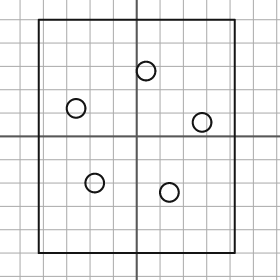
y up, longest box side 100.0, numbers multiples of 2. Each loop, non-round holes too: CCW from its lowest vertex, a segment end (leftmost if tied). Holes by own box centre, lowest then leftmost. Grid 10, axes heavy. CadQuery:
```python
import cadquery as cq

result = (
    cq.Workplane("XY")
    .moveTo(-42.0, -50.0)
    .lineTo(42.0, -50.0)
    .lineTo(42.0, 50.0)
    .lineTo(-42.0, 50.0)
    .close()
    .moveTo(14.0, -24.0)
    .circle(4.0)
    .moveTo(-18.0, -20.0)
    .circle(4.0)
    .moveTo(28.0, 6.0)
    .circle(4.0)
    .moveTo(-26.0, 12.0)
    .circle(4.0)
    .moveTo(4.0, 28.0)
    .circle(4.0)
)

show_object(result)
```